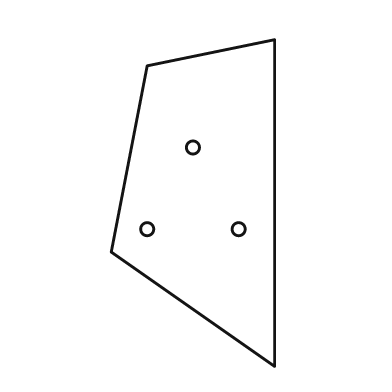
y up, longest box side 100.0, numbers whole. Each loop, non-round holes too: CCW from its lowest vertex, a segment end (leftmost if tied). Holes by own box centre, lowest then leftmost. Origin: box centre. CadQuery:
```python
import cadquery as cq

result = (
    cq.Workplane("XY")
    .moveTo(25.0, -50.0)
    .lineTo(25.0, 50.0)
    .lineTo(-14.0, 42.0)
    .lineTo(-25.0, -15.0)
    .close()
    .moveTo(-14.0, -8.0)
    .circle(2.0)
    .moveTo(14.0, -8.0)
    .circle(2.0)
    .moveTo(0.0, 17.0)
    .circle(2.0)
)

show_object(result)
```